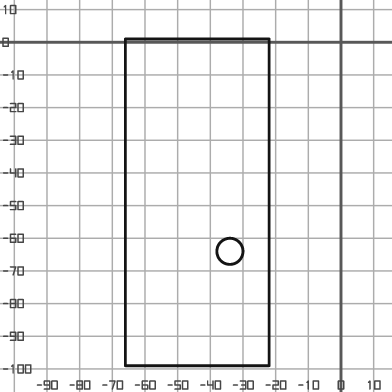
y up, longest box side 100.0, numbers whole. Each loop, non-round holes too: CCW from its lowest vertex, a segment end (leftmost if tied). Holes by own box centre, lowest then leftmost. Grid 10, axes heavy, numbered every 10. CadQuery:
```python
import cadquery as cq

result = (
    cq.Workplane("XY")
    .moveTo(-66.0, -99.0)
    .lineTo(-22.0, -99.0)
    .lineTo(-22.0, 1.0)
    .lineTo(-66.0, 1.0)
    .close()
    .moveTo(-34.0, -64.0)
    .circle(4.0)
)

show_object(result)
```